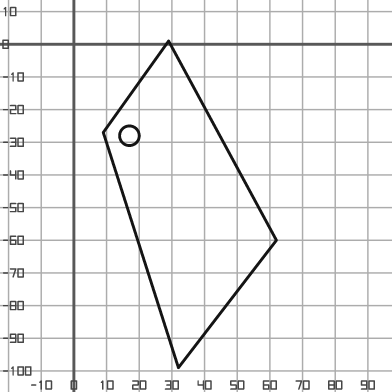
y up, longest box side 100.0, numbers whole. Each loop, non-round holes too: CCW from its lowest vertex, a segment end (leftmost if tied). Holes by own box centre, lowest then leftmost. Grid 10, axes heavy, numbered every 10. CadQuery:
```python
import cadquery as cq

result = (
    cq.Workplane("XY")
    .moveTo(32.0, -99.0)
    .lineTo(62.0, -60.0)
    .lineTo(29.0, 1.0)
    .lineTo(9.0, -27.0)
    .close()
    .moveTo(17.0, -28.0)
    .circle(3.0)
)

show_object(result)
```